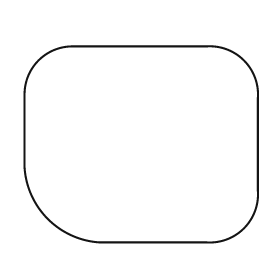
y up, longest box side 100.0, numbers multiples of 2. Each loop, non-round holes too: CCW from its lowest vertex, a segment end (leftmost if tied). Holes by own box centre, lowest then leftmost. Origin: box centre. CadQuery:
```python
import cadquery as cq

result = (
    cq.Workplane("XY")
    .moveTo(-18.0, -42.0)
    .lineTo(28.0, -42.0)
    .threePointArc((44.0, -36.0), (50.0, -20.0))
    .lineTo(50.0, 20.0)
    .threePointArc((44.0, 36.0), (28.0, 42.0))
    .lineTo(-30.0, 42.0)
    .threePointArc((-44.0, 36.0), (-50.0, 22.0))
    .lineTo(-50.0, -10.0)
    .threePointArc((-40.0, -32.0), (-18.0, -42.0))
    .close()
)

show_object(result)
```